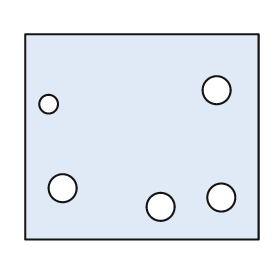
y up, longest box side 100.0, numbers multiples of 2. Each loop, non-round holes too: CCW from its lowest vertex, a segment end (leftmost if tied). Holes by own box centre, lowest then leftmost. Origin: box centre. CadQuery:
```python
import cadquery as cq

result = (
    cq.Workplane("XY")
    .moveTo(-50.0, -44.0)
    .lineTo(50.0, -44.0)
    .lineTo(50.0, 44.0)
    .lineTo(-50.0, 44.0)
    .close()
    .moveTo(8.0, -30.0)
    .circle(6.0)
    .moveTo(34.0, -26.0)
    .circle(6.0)
    .moveTo(-34.0, -22.0)
    .circle(6.0)
    .moveTo(-40.0, 14.0)
    .circle(4.0)
    .moveTo(32.0, 20.0)
    .circle(6.0)
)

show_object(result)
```